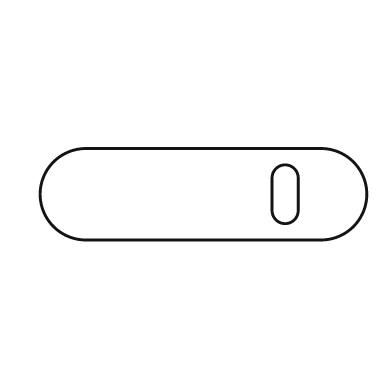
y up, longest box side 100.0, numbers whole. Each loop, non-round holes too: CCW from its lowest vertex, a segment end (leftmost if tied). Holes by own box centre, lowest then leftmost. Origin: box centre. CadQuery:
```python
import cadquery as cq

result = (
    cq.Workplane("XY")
    .moveTo(-36.0, -14.0)
    .lineTo(36.0, -14.0)
    .threePointArc((50.0, 0.0), (36.0, 14.0))
    .lineTo(-36.0, 14.0)
    .threePointArc((-50.0, 0.0), (-36.0, -14.0))
    .close()
    .moveTo(21.0, -5.0)
    .threePointArc((25.0, -9.0), (29.0, -5.0))
    .lineTo(29.0, 5.0)
    .threePointArc((25.0, 9.0), (21.0, 5.0))
    .close()
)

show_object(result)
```